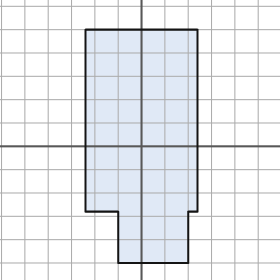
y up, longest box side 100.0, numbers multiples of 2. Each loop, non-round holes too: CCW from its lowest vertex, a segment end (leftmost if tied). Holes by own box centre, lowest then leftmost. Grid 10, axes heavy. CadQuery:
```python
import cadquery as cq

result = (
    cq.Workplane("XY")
    .moveTo(-10.0, -50.0)
    .lineTo(20.0, -50.0)
    .lineTo(20.0, -28.0)
    .lineTo(24.0, -28.0)
    .lineTo(24.0, 50.0)
    .lineTo(-24.0, 50.0)
    .lineTo(-24.0, -28.0)
    .lineTo(-10.0, -28.0)
    .close()
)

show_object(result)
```